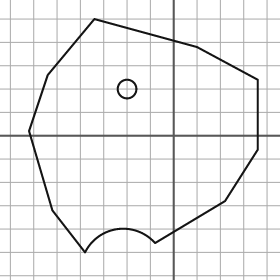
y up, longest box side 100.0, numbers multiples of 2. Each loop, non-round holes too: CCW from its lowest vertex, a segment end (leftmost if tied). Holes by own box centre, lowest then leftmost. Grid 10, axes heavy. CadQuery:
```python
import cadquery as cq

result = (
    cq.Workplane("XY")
    .moveTo(-38.0, -50.0)
    .threePointArc((-24.0, -40.0), (-8.0, -46.0))
    .lineTo(22.0, -28.0)
    .lineTo(36.0, -6.0)
    .lineTo(36.0, 24.0)
    .lineTo(10.0, 38.0)
    .lineTo(-34.0, 50.0)
    .lineTo(-54.0, 26.0)
    .lineTo(-62.0, 2.0)
    .lineTo(-52.0, -32.0)
    .close()
    .moveTo(-20.0, 20.0)
    .circle(4.0)
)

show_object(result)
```